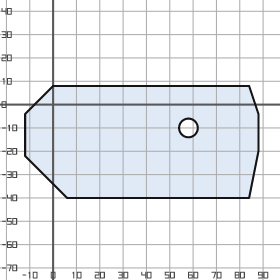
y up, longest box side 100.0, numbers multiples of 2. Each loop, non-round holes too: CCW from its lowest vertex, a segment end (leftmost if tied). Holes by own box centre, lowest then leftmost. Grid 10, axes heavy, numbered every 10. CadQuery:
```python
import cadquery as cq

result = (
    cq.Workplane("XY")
    .moveTo(6.0, -40.0)
    .lineTo(84.0, -40.0)
    .lineTo(88.0, -20.0)
    .lineTo(88.0, -4.0)
    .lineTo(84.0, 8.0)
    .lineTo(0.0, 8.0)
    .lineTo(-12.0, -4.0)
    .lineTo(-12.0, -22.0)
    .close()
    .moveTo(58.0, -10.0)
    .circle(4.0)
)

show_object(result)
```